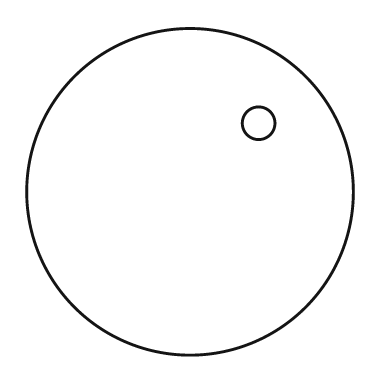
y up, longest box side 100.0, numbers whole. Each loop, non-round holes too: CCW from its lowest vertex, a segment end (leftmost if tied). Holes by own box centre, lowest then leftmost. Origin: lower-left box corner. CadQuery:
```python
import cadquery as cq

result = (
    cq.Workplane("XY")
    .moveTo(50.0, 50.0)
    .circle(50.0)
    .moveTo(71.0, 71.0)
    .circle(5.0)
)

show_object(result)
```